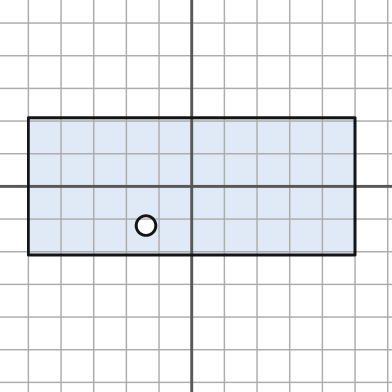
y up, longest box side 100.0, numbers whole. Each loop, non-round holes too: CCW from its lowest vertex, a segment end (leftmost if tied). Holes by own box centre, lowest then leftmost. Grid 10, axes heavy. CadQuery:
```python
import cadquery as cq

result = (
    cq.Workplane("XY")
    .moveTo(-50.0, -21.0)
    .lineTo(50.0, -21.0)
    .lineTo(50.0, 21.0)
    .lineTo(-50.0, 21.0)
    .close()
    .moveTo(-14.0, -12.0)
    .circle(3.0)
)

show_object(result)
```